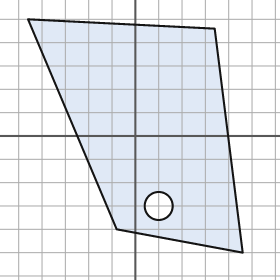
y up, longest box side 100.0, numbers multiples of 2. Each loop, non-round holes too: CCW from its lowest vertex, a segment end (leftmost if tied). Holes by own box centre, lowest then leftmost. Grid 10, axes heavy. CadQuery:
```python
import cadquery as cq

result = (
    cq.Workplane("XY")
    .moveTo(46.0, -50.0)
    .lineTo(34.0, 46.0)
    .lineTo(-46.0, 50.0)
    .lineTo(-8.0, -40.0)
    .close()
    .moveTo(10.0, -30.0)
    .circle(6.0)
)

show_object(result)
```